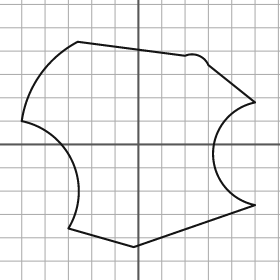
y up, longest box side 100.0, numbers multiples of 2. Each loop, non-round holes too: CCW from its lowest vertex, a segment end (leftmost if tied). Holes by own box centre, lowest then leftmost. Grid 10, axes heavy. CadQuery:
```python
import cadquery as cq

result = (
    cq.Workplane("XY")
    .moveTo(-2.0, -44.0)
    .lineTo(50.0, -26.0)
    .threePointArc((32.0, -4.0), (50.0, 18.0))
    .lineTo(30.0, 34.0)
    .threePointArc((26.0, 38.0), (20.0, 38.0))
    .lineTo(-26.0, 44.0)
    .threePointArc((-42.0, 30.0), (-50.0, 10.0))
    .threePointArc((-28.0, -8.0), (-30.0, -36.0))
    .close()
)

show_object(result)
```